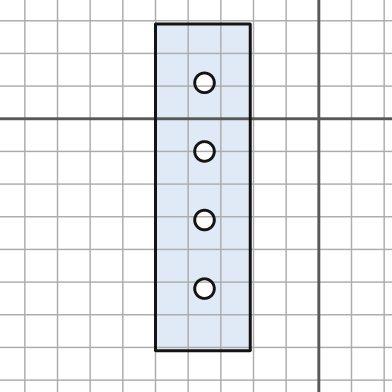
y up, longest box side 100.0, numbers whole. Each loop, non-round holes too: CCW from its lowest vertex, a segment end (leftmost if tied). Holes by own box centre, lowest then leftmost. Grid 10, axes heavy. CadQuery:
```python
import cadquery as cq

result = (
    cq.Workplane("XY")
    .moveTo(-50.0, -71.0)
    .lineTo(-21.0, -71.0)
    .lineTo(-21.0, 29.0)
    .lineTo(-50.0, 29.0)
    .close()
    .moveTo(-35.0, -52.0)
    .circle(3.0)
    .moveTo(-35.0, -31.0)
    .circle(3.0)
    .moveTo(-35.0, -10.0)
    .circle(3.0)
    .moveTo(-35.0, 11.0)
    .circle(3.0)
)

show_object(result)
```